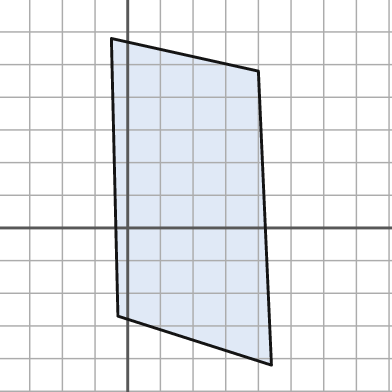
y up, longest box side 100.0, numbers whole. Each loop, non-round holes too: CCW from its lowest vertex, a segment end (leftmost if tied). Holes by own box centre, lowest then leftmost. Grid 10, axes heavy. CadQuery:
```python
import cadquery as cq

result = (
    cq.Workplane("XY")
    .moveTo(44.0, -42.0)
    .lineTo(40.0, 48.0)
    .lineTo(-5.0, 58.0)
    .lineTo(-3.0, -27.0)
    .close()
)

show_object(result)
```